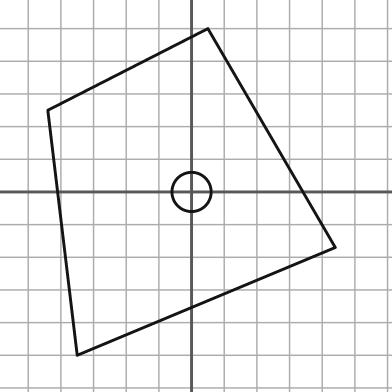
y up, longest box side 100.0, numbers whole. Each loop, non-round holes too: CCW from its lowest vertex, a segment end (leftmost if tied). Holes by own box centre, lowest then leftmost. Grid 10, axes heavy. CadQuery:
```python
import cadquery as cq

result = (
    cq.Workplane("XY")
    .moveTo(-35.0, -50.0)
    .lineTo(44.0, -17.0)
    .lineTo(5.0, 50.0)
    .lineTo(-44.0, 25.0)
    .close()
    .moveTo(0.0, 0.0)
    .circle(6.0)
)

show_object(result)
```